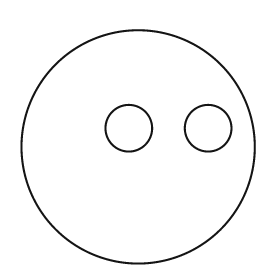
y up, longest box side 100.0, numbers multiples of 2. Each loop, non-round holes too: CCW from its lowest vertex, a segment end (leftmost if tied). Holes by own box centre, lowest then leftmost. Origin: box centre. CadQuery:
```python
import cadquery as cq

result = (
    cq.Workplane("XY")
    .moveTo(0.0, 0.0)
    .circle(50.0)
    .moveTo(-4.0, 8.0)
    .circle(10.0)
    .moveTo(30.0, 8.0)
    .circle(10.0)
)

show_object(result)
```